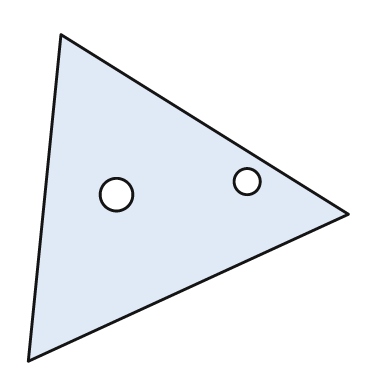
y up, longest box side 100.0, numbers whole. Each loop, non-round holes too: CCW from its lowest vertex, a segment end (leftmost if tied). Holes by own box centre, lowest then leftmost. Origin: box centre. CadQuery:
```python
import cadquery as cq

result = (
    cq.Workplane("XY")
    .moveTo(-49.0, -50.0)
    .lineTo(49.0, -5.0)
    .lineTo(-39.0, 50.0)
    .close()
    .moveTo(-22.0, 1.0)
    .circle(5.0)
    .moveTo(18.0, 5.0)
    .circle(4.0)
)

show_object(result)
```